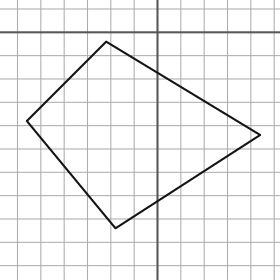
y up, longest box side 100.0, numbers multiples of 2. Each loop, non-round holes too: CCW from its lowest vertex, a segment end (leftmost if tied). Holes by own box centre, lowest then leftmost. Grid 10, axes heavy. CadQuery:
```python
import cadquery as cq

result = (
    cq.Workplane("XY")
    .moveTo(-18.0, -84.0)
    .lineTo(44.0, -44.0)
    .lineTo(-22.0, -4.0)
    .lineTo(-56.0, -38.0)
    .close()
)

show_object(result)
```